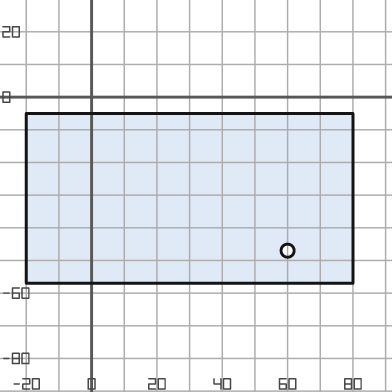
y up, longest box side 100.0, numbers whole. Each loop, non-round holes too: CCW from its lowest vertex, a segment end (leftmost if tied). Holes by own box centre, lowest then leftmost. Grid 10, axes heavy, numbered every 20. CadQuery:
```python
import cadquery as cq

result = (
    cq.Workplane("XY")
    .moveTo(-20.0, -57.0)
    .lineTo(80.0, -57.0)
    .lineTo(80.0, -5.0)
    .lineTo(-20.0, -5.0)
    .close()
    .moveTo(60.0, -47.0)
    .circle(2.0)
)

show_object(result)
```